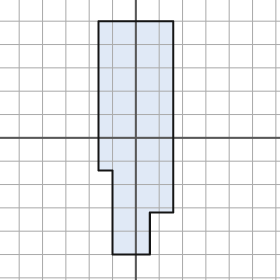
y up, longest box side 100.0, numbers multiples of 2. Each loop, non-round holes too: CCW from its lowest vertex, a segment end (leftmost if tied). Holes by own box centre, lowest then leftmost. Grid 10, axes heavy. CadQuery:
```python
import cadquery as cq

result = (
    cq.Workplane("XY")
    .moveTo(-10.0, -50.0)
    .lineTo(6.0, -50.0)
    .lineTo(6.0, -32.0)
    .lineTo(16.0, -32.0)
    .lineTo(16.0, 50.0)
    .lineTo(-16.0, 50.0)
    .lineTo(-16.0, -14.0)
    .lineTo(-10.0, -14.0)
    .close()
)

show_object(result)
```